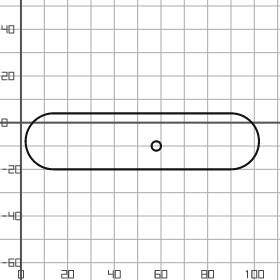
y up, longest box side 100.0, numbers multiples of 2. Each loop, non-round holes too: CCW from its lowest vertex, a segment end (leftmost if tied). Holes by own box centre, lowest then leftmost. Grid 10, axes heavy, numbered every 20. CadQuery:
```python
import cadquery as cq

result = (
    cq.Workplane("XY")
    .moveTo(14.0, -20.0)
    .lineTo(90.0, -20.0)
    .threePointArc((102.0, -8.0), (90.0, 4.0))
    .lineTo(14.0, 4.0)
    .threePointArc((2.0, -8.0), (14.0, -20.0))
    .close()
    .moveTo(58.0, -10.0)
    .circle(2.0)
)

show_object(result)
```